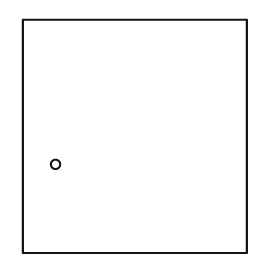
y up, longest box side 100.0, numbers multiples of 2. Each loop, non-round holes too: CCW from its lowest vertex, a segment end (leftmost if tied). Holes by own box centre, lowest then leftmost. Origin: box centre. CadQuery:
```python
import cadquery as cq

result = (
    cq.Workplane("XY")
    .moveTo(-48.0, -50.0)
    .lineTo(48.0, -50.0)
    .lineTo(48.0, 50.0)
    .lineTo(-48.0, 50.0)
    .close()
    .moveTo(-34.0, -12.0)
    .circle(2.0)
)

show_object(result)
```